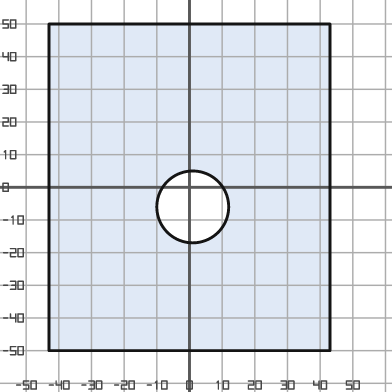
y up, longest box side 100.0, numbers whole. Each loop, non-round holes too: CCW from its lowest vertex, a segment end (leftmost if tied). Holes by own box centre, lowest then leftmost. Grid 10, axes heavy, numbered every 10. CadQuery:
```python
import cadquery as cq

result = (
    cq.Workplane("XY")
    .moveTo(-43.0, -50.0)
    .lineTo(43.0, -50.0)
    .lineTo(43.0, 50.0)
    .lineTo(-43.0, 50.0)
    .close()
    .moveTo(1.0, -6.0)
    .circle(11.0)
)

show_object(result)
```